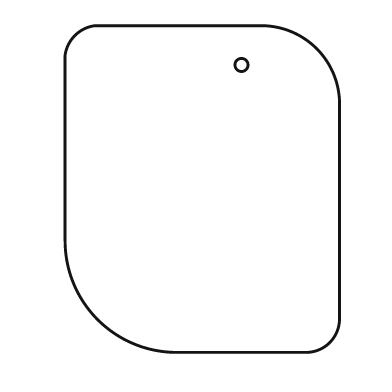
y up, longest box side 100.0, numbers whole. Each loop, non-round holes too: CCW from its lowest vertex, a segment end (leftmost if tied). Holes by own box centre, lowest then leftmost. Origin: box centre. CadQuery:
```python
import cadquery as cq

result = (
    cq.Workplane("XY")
    .moveTo(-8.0, -50.0)
    .lineTo(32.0, -50.0)
    .threePointArc((39.0, -47.0), (42.0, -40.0))
    .lineTo(42.0, 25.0)
    .threePointArc((35.0, 43.0), (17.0, 50.0))
    .lineTo(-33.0, 50.0)
    .threePointArc((-39.0, 47.0), (-42.0, 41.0))
    .lineTo(-42.0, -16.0)
    .threePointArc((-32.0, -40.0), (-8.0, -50.0))
    .close()
    .moveTo(12.0, 38.0)
    .circle(2.0)
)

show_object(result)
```